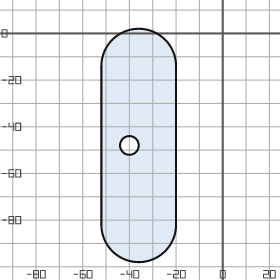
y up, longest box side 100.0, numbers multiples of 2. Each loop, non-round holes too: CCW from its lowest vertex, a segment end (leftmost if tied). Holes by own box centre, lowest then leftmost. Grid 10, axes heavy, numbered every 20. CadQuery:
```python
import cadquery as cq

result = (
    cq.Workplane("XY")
    .moveTo(-52.0, -82.0)
    .threePointArc((-36.0, -98.0), (-20.0, -82.0))
    .lineTo(-20.0, -14.0)
    .threePointArc((-36.0, 2.0), (-52.0, -14.0))
    .close()
    .moveTo(-40.0, -48.0)
    .circle(4.0)
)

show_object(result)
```